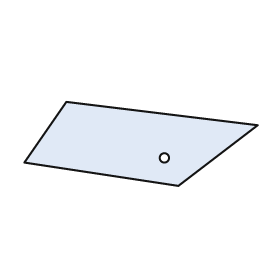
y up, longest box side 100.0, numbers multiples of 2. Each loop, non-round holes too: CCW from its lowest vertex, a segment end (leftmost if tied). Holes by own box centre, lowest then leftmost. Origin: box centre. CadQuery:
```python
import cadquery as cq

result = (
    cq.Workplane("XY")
    .moveTo(16.0, -18.0)
    .lineTo(50.0, 8.0)
    .lineTo(-32.0, 18.0)
    .lineTo(-50.0, -8.0)
    .close()
    .moveTo(10.0, -6.0)
    .circle(2.0)
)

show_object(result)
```